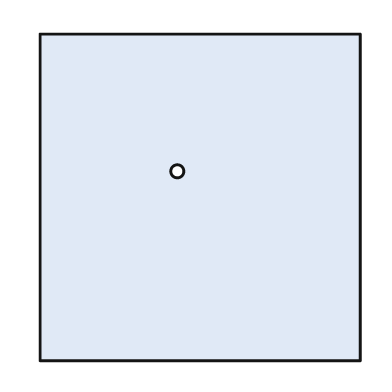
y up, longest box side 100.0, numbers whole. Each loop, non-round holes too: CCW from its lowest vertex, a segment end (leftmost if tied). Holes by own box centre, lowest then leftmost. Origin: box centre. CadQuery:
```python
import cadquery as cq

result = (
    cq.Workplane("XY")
    .moveTo(-49.0, -50.0)
    .lineTo(49.0, -50.0)
    .lineTo(49.0, 50.0)
    .lineTo(-49.0, 50.0)
    .close()
    .moveTo(-7.0, 8.0)
    .circle(2.0)
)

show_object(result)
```